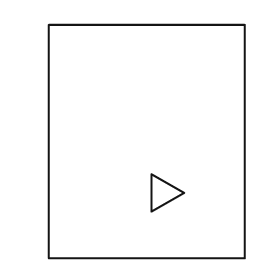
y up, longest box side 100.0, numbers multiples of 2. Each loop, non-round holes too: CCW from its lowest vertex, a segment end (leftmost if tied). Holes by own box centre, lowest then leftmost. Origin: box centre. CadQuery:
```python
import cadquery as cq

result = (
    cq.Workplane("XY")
    .moveTo(-42.0, -50.0)
    .lineTo(42.0, -50.0)
    .lineTo(42.0, 50.0)
    .lineTo(-42.0, 50.0)
    .close()
    .moveTo(2.0, -30.0)
    .lineTo(16.0, -22.0)
    .lineTo(2.0, -14.0)
    .close()
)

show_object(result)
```